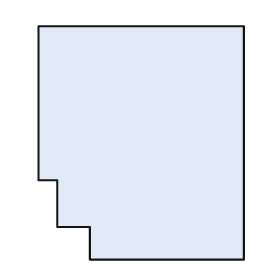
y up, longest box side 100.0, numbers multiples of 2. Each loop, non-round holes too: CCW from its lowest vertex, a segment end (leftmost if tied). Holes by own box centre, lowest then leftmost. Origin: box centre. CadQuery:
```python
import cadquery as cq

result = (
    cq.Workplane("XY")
    .moveTo(-22.0, -50.0)
    .lineTo(44.0, -50.0)
    .lineTo(44.0, 50.0)
    .lineTo(-44.0, 50.0)
    .lineTo(-44.0, -16.0)
    .lineTo(-36.0, -16.0)
    .lineTo(-36.0, -36.0)
    .lineTo(-22.0, -36.0)
    .close()
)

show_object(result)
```